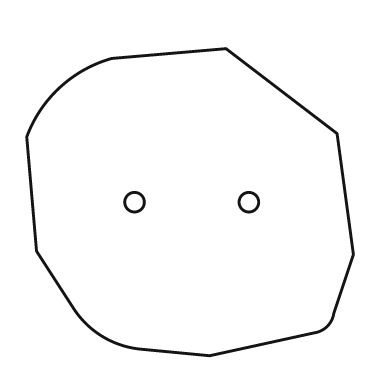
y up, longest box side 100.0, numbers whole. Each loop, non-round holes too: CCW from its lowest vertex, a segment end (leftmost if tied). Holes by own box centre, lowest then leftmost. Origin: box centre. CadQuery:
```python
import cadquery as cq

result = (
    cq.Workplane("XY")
    .moveTo(6.0, -47.0)
    .lineTo(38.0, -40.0)
    .threePointArc((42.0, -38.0), (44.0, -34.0))
    .lineTo(50.0, -16.0)
    .lineTo(45.0, 21.0)
    .lineTo(11.0, 47.0)
    .lineTo(-24.0, 44.0)
    .threePointArc((-40.0, 35.0), (-50.0, 20.0))
    .lineTo(-47.0, -15.0)
    .lineTo(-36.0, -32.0)
    .threePointArc((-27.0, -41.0), (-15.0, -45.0))
    .close()
    .moveTo(-17.0, 0.0)
    .circle(3.0)
    .moveTo(18.0, 0.0)
    .circle(3.0)
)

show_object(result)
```